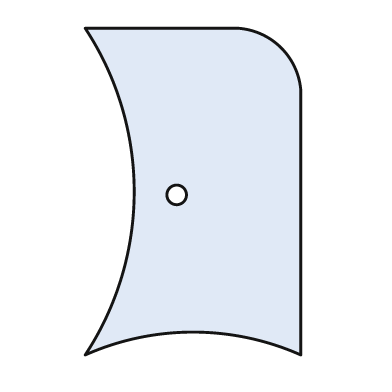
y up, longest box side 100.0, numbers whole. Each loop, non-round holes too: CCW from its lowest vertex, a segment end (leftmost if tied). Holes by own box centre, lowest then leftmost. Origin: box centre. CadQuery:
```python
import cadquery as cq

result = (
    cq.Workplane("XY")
    .moveTo(-33.0, -50.0)
    .threePointArc((0.0, -43.0), (33.0, -50.0))
    .lineTo(33.0, 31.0)
    .threePointArc((27.0, 44.0), (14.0, 50.0))
    .lineTo(-33.0, 50.0)
    .threePointArc((-18.0, 0.0), (-33.0, -50.0))
    .close()
    .moveTo(-5.0, -1.0)
    .circle(3.0)
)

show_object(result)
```